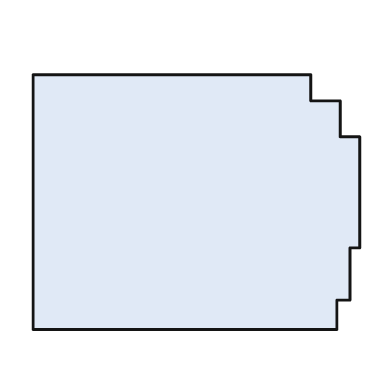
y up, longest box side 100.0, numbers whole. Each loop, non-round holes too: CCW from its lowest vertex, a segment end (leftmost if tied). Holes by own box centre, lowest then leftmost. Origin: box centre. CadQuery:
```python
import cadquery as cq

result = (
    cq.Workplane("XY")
    .moveTo(-50.0, -39.0)
    .lineTo(43.0, -39.0)
    .lineTo(43.0, -30.0)
    .lineTo(47.0, -30.0)
    .lineTo(47.0, -14.0)
    .lineTo(50.0, -14.0)
    .lineTo(50.0, 20.0)
    .lineTo(44.0, 20.0)
    .lineTo(44.0, 31.0)
    .lineTo(35.0, 31.0)
    .lineTo(35.0, 39.0)
    .lineTo(-50.0, 39.0)
    .close()
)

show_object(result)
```